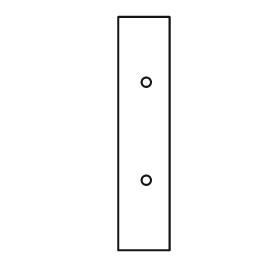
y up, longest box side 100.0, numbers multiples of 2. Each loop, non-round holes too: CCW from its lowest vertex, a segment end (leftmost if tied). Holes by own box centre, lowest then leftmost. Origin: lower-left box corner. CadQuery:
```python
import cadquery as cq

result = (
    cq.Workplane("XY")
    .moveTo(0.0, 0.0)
    .lineTo(22.0, 0.0)
    .lineTo(22.0, 100.0)
    .lineTo(0.0, 100.0)
    .close()
    .moveTo(12.0, 30.0)
    .circle(2.0)
    .moveTo(12.0, 72.0)
    .circle(2.0)
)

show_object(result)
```